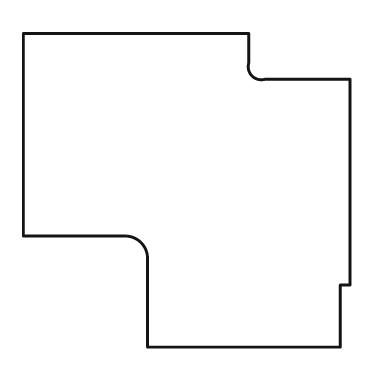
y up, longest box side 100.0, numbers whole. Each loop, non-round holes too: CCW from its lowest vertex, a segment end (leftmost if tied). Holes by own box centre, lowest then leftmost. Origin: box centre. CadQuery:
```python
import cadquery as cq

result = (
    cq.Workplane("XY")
    .moveTo(-12.0, -48.0)
    .lineTo(47.0, -48.0)
    .lineTo(47.0, -29.0)
    .lineTo(50.0, -29.0)
    .lineTo(50.0, 34.0)
    .lineTo(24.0, 34.0)
    .threePointArc((20.0, 35.0), (19.0, 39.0))
    .lineTo(19.0, 48.0)
    .lineTo(-50.0, 48.0)
    .lineTo(-50.0, -14.0)
    .lineTo(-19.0, -14.0)
    .threePointArc((-14.0, -16.0), (-12.0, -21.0))
    .close()
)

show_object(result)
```